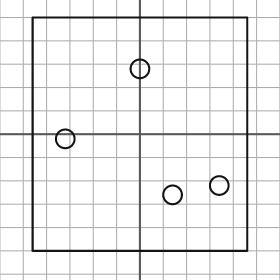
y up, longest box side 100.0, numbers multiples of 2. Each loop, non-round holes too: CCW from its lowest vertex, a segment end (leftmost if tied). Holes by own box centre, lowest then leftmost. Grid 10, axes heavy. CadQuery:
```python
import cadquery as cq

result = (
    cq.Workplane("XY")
    .moveTo(-46.0, -50.0)
    .lineTo(46.0, -50.0)
    .lineTo(46.0, 50.0)
    .lineTo(-46.0, 50.0)
    .close()
    .moveTo(14.0, -26.0)
    .circle(4.0)
    .moveTo(34.0, -22.0)
    .circle(4.0)
    .moveTo(-32.0, -2.0)
    .circle(4.0)
    .moveTo(0.0, 28.0)
    .circle(4.0)
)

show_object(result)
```